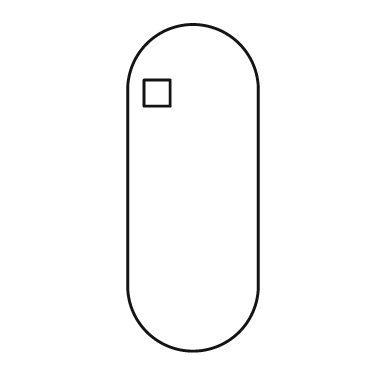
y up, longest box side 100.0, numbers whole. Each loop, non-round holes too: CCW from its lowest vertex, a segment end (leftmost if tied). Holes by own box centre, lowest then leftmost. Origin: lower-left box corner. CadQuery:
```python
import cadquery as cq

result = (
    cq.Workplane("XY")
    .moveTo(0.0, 20.0)
    .threePointArc((20.0, 0.0), (40.0, 20.0))
    .lineTo(40.0, 80.0)
    .threePointArc((20.0, 100.0), (0.0, 80.0))
    .close()
    .moveTo(5.0, 75.0)
    .lineTo(13.0, 75.0)
    .lineTo(13.0, 83.0)
    .lineTo(5.0, 83.0)
    .close()
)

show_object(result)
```